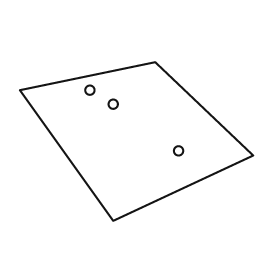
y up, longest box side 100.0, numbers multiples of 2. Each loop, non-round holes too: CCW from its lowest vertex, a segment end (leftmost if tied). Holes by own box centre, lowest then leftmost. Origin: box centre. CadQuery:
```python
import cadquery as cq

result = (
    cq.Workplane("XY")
    .moveTo(-10.0, -34.0)
    .lineTo(50.0, -6.0)
    .lineTo(8.0, 34.0)
    .lineTo(-50.0, 22.0)
    .close()
    .moveTo(18.0, -4.0)
    .circle(2.0)
    .moveTo(-10.0, 16.0)
    .circle(2.0)
    .moveTo(-20.0, 22.0)
    .circle(2.0)
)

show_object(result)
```